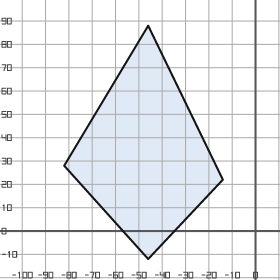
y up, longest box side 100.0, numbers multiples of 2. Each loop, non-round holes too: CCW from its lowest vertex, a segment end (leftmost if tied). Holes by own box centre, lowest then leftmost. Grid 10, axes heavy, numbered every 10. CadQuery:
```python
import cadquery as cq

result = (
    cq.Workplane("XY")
    .moveTo(-46.0, -12.0)
    .lineTo(-14.0, 22.0)
    .lineTo(-46.0, 88.0)
    .lineTo(-82.0, 28.0)
    .close()
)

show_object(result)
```